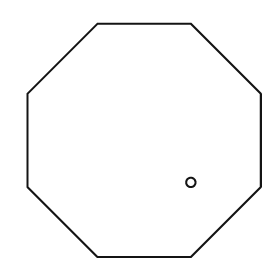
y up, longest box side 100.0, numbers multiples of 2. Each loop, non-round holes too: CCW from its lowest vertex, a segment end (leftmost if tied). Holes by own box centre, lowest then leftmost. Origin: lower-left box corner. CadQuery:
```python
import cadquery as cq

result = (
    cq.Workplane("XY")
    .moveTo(30.0, 0.0)
    .lineTo(70.0, 0.0)
    .lineTo(100.0, 30.0)
    .lineTo(100.0, 70.0)
    .lineTo(70.0, 100.0)
    .lineTo(30.0, 100.0)
    .lineTo(0.0, 70.0)
    .lineTo(0.0, 30.0)
    .close()
    .moveTo(70.0, 32.0)
    .circle(2.0)
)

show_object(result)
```